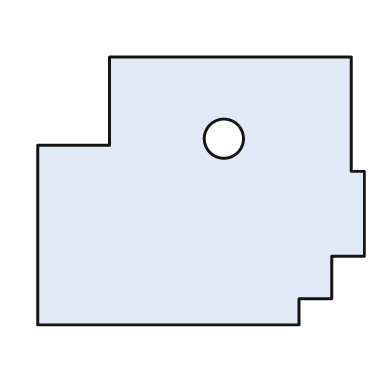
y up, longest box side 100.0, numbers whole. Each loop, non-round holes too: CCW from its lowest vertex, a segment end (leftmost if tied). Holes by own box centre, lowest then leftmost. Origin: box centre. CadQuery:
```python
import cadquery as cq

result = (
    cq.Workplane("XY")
    .moveTo(-50.0, -41.0)
    .lineTo(30.0, -41.0)
    .lineTo(30.0, -33.0)
    .lineTo(40.0, -33.0)
    .lineTo(40.0, -20.0)
    .lineTo(50.0, -20.0)
    .lineTo(50.0, 6.0)
    .lineTo(46.0, 6.0)
    .lineTo(46.0, 41.0)
    .lineTo(-28.0, 41.0)
    .lineTo(-28.0, 14.0)
    .lineTo(-50.0, 14.0)
    .close()
    .moveTo(7.0, 16.0)
    .circle(6.0)
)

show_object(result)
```